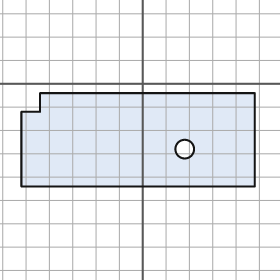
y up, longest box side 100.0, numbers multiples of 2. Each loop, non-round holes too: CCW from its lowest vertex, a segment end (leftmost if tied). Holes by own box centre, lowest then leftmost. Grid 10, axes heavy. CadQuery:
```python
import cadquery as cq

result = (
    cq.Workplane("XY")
    .moveTo(-52.0, -44.0)
    .lineTo(48.0, -44.0)
    .lineTo(48.0, -4.0)
    .lineTo(-44.0, -4.0)
    .lineTo(-44.0, -12.0)
    .lineTo(-52.0, -12.0)
    .close()
    .moveTo(18.0, -28.0)
    .circle(4.0)
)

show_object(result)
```